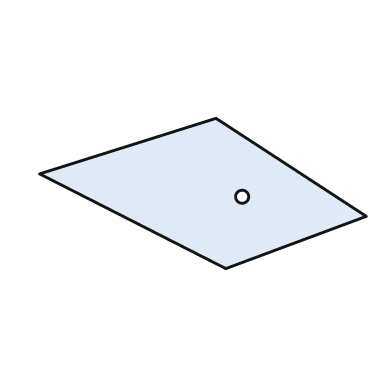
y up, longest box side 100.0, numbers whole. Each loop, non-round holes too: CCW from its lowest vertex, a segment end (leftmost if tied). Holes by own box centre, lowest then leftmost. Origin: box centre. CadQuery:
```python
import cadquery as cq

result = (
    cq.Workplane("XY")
    .moveTo(7.0, -23.0)
    .lineTo(50.0, -7.0)
    .lineTo(4.0, 23.0)
    .lineTo(-50.0, 6.0)
    .close()
    .moveTo(12.0, -1.0)
    .circle(2.0)
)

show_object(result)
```